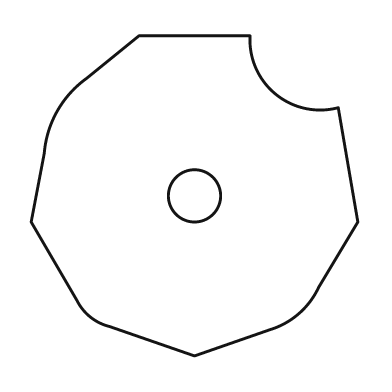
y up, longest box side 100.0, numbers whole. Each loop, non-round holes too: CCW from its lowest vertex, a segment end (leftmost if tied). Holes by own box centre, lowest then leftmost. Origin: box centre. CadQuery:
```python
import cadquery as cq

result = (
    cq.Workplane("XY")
    .moveTo(0.0, -49.0)
    .lineTo(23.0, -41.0)
    .threePointArc((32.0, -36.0), (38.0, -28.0))
    .lineTo(50.0, -8.0)
    .lineTo(44.0, 27.0)
    .threePointArc((25.0, 31.0), (17.0, 49.0))
    .lineTo(-17.0, 49.0)
    .lineTo(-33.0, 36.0)
    .threePointArc((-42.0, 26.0), (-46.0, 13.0))
    .lineTo(-50.0, -8.0)
    .lineTo(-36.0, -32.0)
    .threePointArc((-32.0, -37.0), (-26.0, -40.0))
    .close()
    .moveTo(0.0, 0.0)
    .circle(8.0)
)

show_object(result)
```